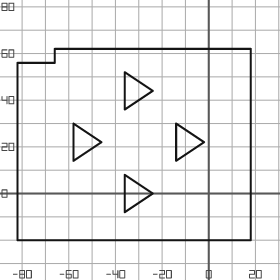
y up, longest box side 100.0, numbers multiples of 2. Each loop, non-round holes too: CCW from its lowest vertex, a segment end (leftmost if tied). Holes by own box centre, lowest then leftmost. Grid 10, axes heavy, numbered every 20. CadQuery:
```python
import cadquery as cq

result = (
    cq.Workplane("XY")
    .moveTo(-82.0, -20.0)
    .lineTo(18.0, -20.0)
    .lineTo(18.0, 62.0)
    .lineTo(-66.0, 62.0)
    .lineTo(-66.0, 56.0)
    .lineTo(-82.0, 56.0)
    .close()
    .moveTo(-36.0, -8.0)
    .lineTo(-24.0, 0.0)
    .lineTo(-36.0, 8.0)
    .close()
    .moveTo(-58.0, 14.0)
    .lineTo(-46.0, 22.0)
    .lineTo(-58.0, 30.0)
    .close()
    .moveTo(-14.0, 14.0)
    .lineTo(-2.0, 22.0)
    .lineTo(-14.0, 30.0)
    .close()
    .moveTo(-36.0, 36.0)
    .lineTo(-24.0, 44.0)
    .lineTo(-36.0, 52.0)
    .close()
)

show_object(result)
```